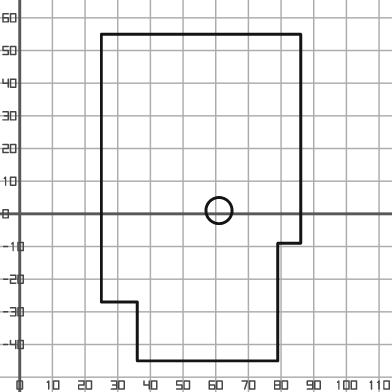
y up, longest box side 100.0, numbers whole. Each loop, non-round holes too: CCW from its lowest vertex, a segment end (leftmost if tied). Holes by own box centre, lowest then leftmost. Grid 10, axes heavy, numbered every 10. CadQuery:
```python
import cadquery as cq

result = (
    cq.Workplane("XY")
    .moveTo(36.0, -45.0)
    .lineTo(79.0, -45.0)
    .lineTo(79.0, -9.0)
    .lineTo(86.0, -9.0)
    .lineTo(86.0, 55.0)
    .lineTo(25.0, 55.0)
    .lineTo(25.0, -27.0)
    .lineTo(36.0, -27.0)
    .close()
    .moveTo(61.0, 1.0)
    .circle(4.0)
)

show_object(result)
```